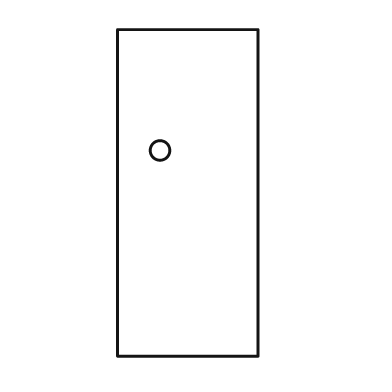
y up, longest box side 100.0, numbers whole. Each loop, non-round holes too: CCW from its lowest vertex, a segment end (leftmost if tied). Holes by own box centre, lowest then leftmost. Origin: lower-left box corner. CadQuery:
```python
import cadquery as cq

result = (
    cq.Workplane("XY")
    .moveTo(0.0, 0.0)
    .lineTo(43.0, 0.0)
    .lineTo(43.0, 100.0)
    .lineTo(0.0, 100.0)
    .close()
    .moveTo(13.0, 63.0)
    .circle(3.0)
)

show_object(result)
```